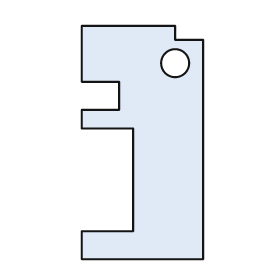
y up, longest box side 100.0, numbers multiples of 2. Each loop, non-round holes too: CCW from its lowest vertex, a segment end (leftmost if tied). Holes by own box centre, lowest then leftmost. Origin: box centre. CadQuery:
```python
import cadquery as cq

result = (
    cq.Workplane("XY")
    .moveTo(-26.0, -50.0)
    .lineTo(26.0, -50.0)
    .lineTo(26.0, 44.0)
    .lineTo(14.0, 44.0)
    .lineTo(14.0, 50.0)
    .lineTo(-26.0, 50.0)
    .lineTo(-26.0, 26.0)
    .lineTo(-10.0, 26.0)
    .lineTo(-10.0, 14.0)
    .lineTo(-26.0, 14.0)
    .lineTo(-26.0, 6.0)
    .lineTo(-4.0, 6.0)
    .lineTo(-4.0, -38.0)
    .lineTo(-26.0, -38.0)
    .close()
    .moveTo(14.0, 34.0)
    .circle(6.0)
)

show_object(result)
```